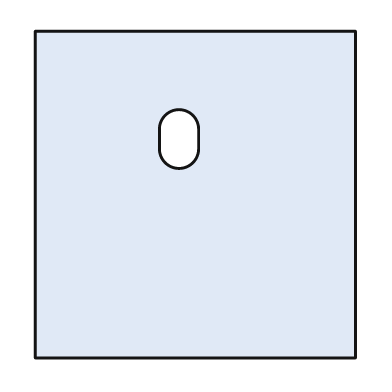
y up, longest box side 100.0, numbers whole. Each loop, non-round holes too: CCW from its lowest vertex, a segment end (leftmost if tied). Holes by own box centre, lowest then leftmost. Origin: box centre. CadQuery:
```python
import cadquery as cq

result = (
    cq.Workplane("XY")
    .moveTo(-49.0, -50.0)
    .lineTo(49.0, -50.0)
    .lineTo(49.0, 50.0)
    .lineTo(-49.0, 50.0)
    .close()
    .moveTo(-11.0, 14.0)
    .threePointArc((-5.0, 8.0), (1.0, 14.0))
    .lineTo(1.0, 20.0)
    .threePointArc((-5.0, 26.0), (-11.0, 20.0))
    .close()
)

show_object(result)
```